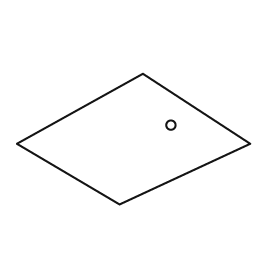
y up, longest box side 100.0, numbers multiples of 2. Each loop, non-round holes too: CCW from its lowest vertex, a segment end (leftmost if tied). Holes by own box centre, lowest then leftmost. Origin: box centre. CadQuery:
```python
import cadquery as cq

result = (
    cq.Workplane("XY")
    .moveTo(-6.0, -28.0)
    .lineTo(50.0, -2.0)
    .lineTo(4.0, 28.0)
    .lineTo(-50.0, -2.0)
    .close()
    .moveTo(16.0, 6.0)
    .circle(2.0)
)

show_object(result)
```